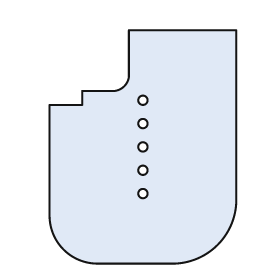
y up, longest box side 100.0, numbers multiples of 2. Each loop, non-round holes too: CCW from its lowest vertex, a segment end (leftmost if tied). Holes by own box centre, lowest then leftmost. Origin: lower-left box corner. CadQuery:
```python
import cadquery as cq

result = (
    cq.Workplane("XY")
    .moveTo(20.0, 0.0)
    .lineTo(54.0, 0.0)
    .threePointArc((72.0, 8.0), (80.0, 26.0))
    .lineTo(80.0, 100.0)
    .lineTo(34.0, 100.0)
    .lineTo(34.0, 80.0)
    .threePointArc((32.0, 76.0), (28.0, 74.0))
    .lineTo(14.0, 74.0)
    .lineTo(14.0, 68.0)
    .lineTo(0.0, 68.0)
    .lineTo(0.0, 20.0)
    .threePointArc((6.0, 6.0), (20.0, 0.0))
    .close()
    .moveTo(40.0, 30.0)
    .circle(2.0)
    .moveTo(40.0, 40.0)
    .circle(2.0)
    .moveTo(40.0, 50.0)
    .circle(2.0)
    .moveTo(40.0, 60.0)
    .circle(2.0)
    .moveTo(40.0, 70.0)
    .circle(2.0)
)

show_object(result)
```